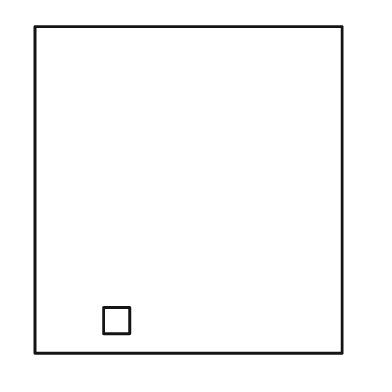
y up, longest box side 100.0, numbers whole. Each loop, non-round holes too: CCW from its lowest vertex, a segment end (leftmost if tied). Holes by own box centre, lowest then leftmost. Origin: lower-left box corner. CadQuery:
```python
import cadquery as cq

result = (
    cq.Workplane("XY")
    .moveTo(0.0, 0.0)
    .lineTo(94.0, 0.0)
    .lineTo(94.0, 100.0)
    .lineTo(0.0, 100.0)
    .close()
    .moveTo(21.0, 6.0)
    .lineTo(29.0, 6.0)
    .lineTo(29.0, 14.0)
    .lineTo(21.0, 14.0)
    .close()
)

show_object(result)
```